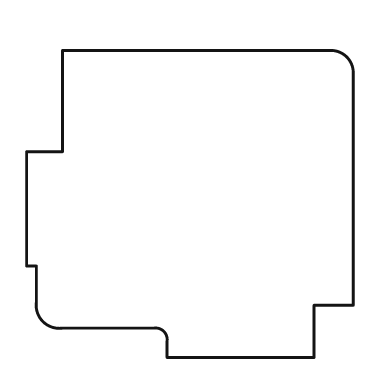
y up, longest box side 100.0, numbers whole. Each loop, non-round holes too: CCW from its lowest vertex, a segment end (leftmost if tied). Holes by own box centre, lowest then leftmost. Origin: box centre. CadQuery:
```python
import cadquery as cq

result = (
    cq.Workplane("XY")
    .moveTo(-7.0, -47.0)
    .lineTo(38.0, -47.0)
    .lineTo(38.0, -31.0)
    .lineTo(50.0, -31.0)
    .lineTo(50.0, 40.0)
    .threePointArc((48.0, 45.0), (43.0, 47.0))
    .lineTo(-39.0, 47.0)
    .lineTo(-39.0, 16.0)
    .lineTo(-50.0, 16.0)
    .lineTo(-50.0, -19.0)
    .lineTo(-47.0, -19.0)
    .lineTo(-47.0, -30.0)
    .threePointArc((-45.0, -36.0), (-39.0, -38.0))
    .lineTo(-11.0, -38.0)
    .threePointArc((-8.0, -39.0), (-7.0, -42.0))
    .close()
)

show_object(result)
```